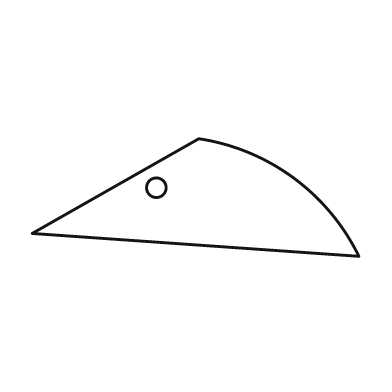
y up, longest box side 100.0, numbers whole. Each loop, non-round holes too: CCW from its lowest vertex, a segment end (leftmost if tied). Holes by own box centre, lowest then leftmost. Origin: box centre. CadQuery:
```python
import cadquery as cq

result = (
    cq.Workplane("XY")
    .moveTo(50.0, -18.0)
    .threePointArc((30.0, 6.0), (1.0, 18.0))
    .lineTo(-50.0, -11.0)
    .close()
    .moveTo(-12.0, 3.0)
    .circle(3.0)
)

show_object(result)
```